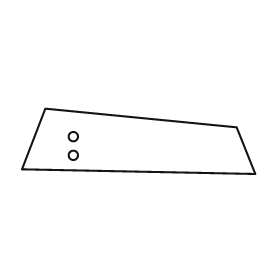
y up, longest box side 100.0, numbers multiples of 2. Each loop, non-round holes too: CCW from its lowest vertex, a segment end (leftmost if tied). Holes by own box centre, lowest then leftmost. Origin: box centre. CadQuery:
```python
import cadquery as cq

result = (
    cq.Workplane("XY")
    .moveTo(50.0, -14.0)
    .lineTo(42.0, 6.0)
    .lineTo(-40.0, 14.0)
    .lineTo(-50.0, -12.0)
    .close()
    .moveTo(-28.0, -6.0)
    .circle(2.0)
    .moveTo(-28.0, 2.0)
    .circle(2.0)
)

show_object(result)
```